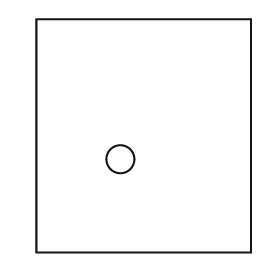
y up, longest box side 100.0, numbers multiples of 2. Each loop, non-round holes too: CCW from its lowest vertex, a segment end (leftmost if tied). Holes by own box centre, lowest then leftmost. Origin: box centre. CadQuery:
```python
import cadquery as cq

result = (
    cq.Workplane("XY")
    .moveTo(-46.0, -50.0)
    .lineTo(46.0, -50.0)
    .lineTo(46.0, 50.0)
    .lineTo(-46.0, 50.0)
    .close()
    .moveTo(-10.0, -10.0)
    .circle(6.0)
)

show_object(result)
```